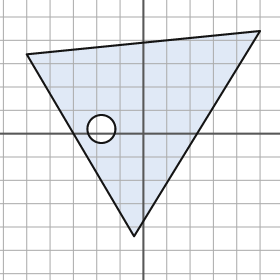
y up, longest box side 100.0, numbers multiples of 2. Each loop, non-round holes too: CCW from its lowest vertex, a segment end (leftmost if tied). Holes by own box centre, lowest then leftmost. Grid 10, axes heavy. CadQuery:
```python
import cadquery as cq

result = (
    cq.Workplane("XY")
    .moveTo(-4.0, -44.0)
    .lineTo(50.0, 44.0)
    .lineTo(-50.0, 34.0)
    .close()
    .moveTo(-18.0, 2.0)
    .circle(6.0)
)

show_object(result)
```